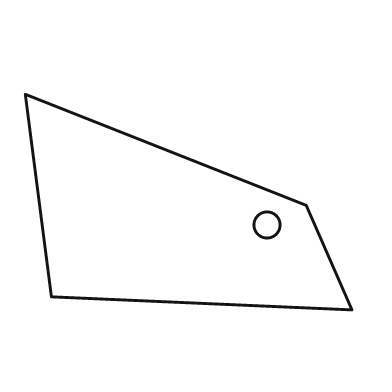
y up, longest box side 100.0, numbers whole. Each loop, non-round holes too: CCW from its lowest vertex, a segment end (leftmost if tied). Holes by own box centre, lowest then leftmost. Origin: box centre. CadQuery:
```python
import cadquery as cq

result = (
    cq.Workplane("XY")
    .moveTo(50.0, -33.0)
    .lineTo(36.0, -1.0)
    .lineTo(-50.0, 33.0)
    .lineTo(-42.0, -29.0)
    .close()
    .moveTo(24.0, -7.0)
    .circle(4.0)
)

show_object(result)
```